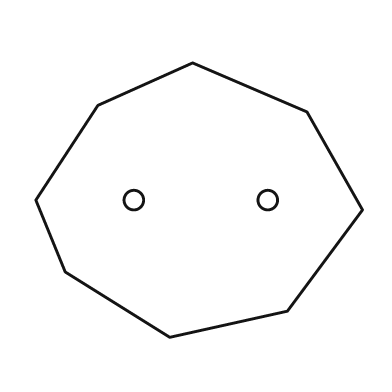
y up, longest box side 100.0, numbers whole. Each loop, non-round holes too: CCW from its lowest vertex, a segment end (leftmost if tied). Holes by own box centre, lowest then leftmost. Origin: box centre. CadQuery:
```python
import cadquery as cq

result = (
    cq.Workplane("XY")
    .moveTo(-9.0, -42.0)
    .lineTo(27.0, -34.0)
    .lineTo(50.0, -3.0)
    .lineTo(33.0, 27.0)
    .lineTo(-2.0, 42.0)
    .lineTo(-31.0, 29.0)
    .lineTo(-50.0, 0.0)
    .lineTo(-41.0, -22.0)
    .close()
    .moveTo(-20.0, 0.0)
    .circle(3.0)
    .moveTo(21.0, 0.0)
    .circle(3.0)
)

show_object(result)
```